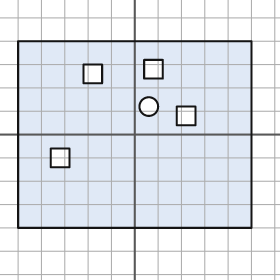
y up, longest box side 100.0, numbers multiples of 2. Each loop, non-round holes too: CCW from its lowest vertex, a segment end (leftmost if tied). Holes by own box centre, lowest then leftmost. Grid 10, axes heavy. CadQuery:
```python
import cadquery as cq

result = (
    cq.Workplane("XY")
    .moveTo(-50.0, -40.0)
    .lineTo(50.0, -40.0)
    .lineTo(50.0, 40.0)
    .lineTo(-50.0, 40.0)
    .close()
    .moveTo(-36.0, -14.0)
    .lineTo(-28.0, -14.0)
    .lineTo(-28.0, -6.0)
    .lineTo(-36.0, -6.0)
    .close()
    .moveTo(18.0, 4.0)
    .lineTo(26.0, 4.0)
    .lineTo(26.0, 12.0)
    .lineTo(18.0, 12.0)
    .close()
    .moveTo(6.0, 12.0)
    .circle(4.0)
    .moveTo(-22.0, 22.0)
    .lineTo(-14.0, 22.0)
    .lineTo(-14.0, 30.0)
    .lineTo(-22.0, 30.0)
    .close()
    .moveTo(4.0, 24.0)
    .lineTo(12.0, 24.0)
    .lineTo(12.0, 32.0)
    .lineTo(4.0, 32.0)
    .close()
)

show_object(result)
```